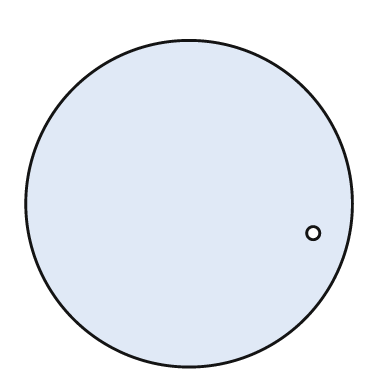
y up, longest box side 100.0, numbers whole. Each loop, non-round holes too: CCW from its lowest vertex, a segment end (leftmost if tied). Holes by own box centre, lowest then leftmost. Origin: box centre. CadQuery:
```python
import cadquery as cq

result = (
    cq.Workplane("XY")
    .moveTo(0.0, 0.0)
    .circle(50.0)
    .moveTo(38.0, -9.0)
    .circle(2.0)
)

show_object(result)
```